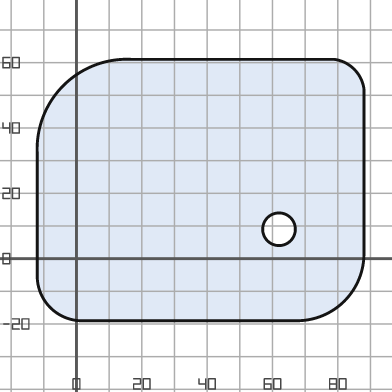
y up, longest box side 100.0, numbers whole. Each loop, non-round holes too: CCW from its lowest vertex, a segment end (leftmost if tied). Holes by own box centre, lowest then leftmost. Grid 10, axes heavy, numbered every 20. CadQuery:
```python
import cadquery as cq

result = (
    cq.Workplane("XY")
    .moveTo(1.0, -19.0)
    .lineTo(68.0, -19.0)
    .threePointArc((82.0, -13.0), (88.0, 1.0))
    .lineTo(88.0, 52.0)
    .threePointArc((85.0, 58.0), (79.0, 61.0))
    .lineTo(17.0, 61.0)
    .threePointArc((-4.0, 53.0), (-12.0, 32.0))
    .lineTo(-12.0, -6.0)
    .threePointArc((-8.0, -15.0), (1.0, -19.0))
    .close()
    .moveTo(62.0, 9.0)
    .circle(5.0)
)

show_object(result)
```